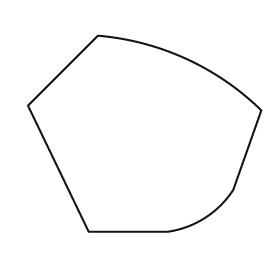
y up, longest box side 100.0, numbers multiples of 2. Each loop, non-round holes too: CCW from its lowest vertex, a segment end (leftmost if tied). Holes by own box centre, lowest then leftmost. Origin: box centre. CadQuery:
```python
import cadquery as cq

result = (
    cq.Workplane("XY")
    .moveTo(-24.0, -42.0)
    .lineTo(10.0, -42.0)
    .threePointArc((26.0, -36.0), (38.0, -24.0))
    .lineTo(50.0, 10.0)
    .threePointArc((18.0, 32.0), (-20.0, 42.0))
    .lineTo(-50.0, 12.0)
    .close()
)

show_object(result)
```